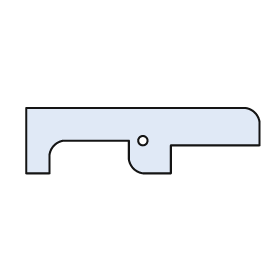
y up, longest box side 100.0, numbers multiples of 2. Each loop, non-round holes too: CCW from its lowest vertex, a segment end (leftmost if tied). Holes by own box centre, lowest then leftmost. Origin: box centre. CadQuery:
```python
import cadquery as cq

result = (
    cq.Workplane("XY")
    .moveTo(-50.0, -14.0)
    .lineTo(-40.0, -14.0)
    .lineTo(-40.0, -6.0)
    .threePointArc((-38.0, -2.0), (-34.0, 0.0))
    .lineTo(-6.0, 0.0)
    .lineTo(-6.0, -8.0)
    .threePointArc((-4.0, -12.0), (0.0, -14.0))
    .lineTo(12.0, -14.0)
    .lineTo(12.0, -2.0)
    .lineTo(50.0, -2.0)
    .lineTo(50.0, 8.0)
    .threePointArc((48.0, 12.0), (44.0, 14.0))
    .lineTo(-50.0, 14.0)
    .close()
    .moveTo(0.0, 0.0)
    .circle(2.0)
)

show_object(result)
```